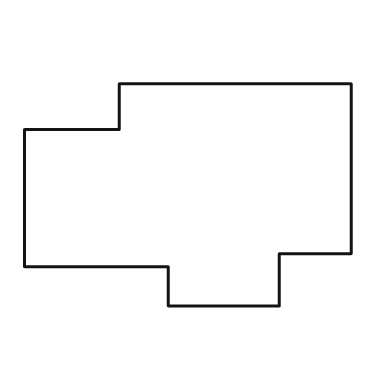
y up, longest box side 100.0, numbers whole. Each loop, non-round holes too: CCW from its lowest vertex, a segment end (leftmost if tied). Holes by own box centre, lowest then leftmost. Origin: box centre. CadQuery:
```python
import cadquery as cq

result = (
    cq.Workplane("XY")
    .moveTo(-6.0, -34.0)
    .lineTo(28.0, -34.0)
    .lineTo(28.0, -18.0)
    .lineTo(50.0, -18.0)
    .lineTo(50.0, 34.0)
    .lineTo(-21.0, 34.0)
    .lineTo(-21.0, 20.0)
    .lineTo(-50.0, 20.0)
    .lineTo(-50.0, -22.0)
    .lineTo(-6.0, -22.0)
    .close()
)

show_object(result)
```